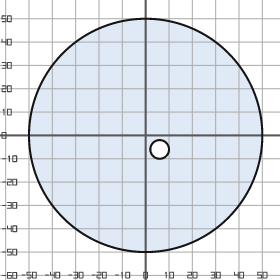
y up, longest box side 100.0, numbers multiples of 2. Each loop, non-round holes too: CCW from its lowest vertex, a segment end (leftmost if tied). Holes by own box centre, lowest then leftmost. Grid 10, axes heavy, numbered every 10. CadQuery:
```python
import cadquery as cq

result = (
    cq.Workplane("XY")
    .moveTo(0.0, 0.0)
    .circle(50.0)
    .moveTo(6.0, -6.0)
    .circle(4.0)
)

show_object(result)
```